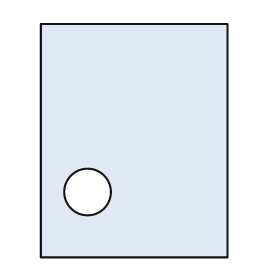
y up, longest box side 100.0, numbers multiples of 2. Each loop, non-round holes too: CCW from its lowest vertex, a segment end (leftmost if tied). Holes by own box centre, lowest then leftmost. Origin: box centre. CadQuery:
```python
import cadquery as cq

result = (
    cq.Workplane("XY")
    .moveTo(-40.0, -50.0)
    .lineTo(40.0, -50.0)
    .lineTo(40.0, 50.0)
    .lineTo(-40.0, 50.0)
    .close()
    .moveTo(-20.0, -22.0)
    .circle(10.0)
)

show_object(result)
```